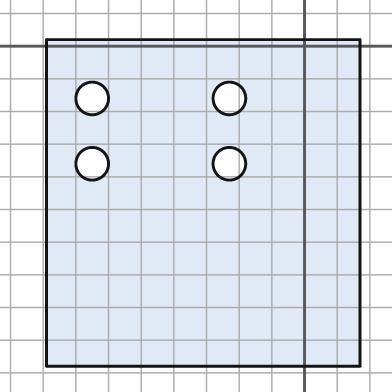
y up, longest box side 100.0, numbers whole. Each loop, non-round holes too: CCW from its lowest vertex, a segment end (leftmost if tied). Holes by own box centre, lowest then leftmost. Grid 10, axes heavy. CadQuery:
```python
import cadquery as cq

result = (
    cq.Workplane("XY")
    .moveTo(-79.0, -98.0)
    .lineTo(17.0, -98.0)
    .lineTo(17.0, 2.0)
    .lineTo(-79.0, 2.0)
    .close()
    .moveTo(-65.0, -36.0)
    .circle(5.0)
    .moveTo(-23.0, -36.0)
    .circle(5.0)
    .moveTo(-65.0, -16.0)
    .circle(5.0)
    .moveTo(-23.0, -16.0)
    .circle(5.0)
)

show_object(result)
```